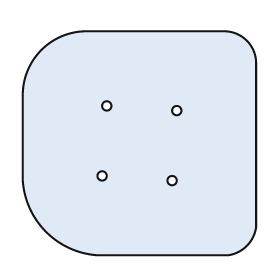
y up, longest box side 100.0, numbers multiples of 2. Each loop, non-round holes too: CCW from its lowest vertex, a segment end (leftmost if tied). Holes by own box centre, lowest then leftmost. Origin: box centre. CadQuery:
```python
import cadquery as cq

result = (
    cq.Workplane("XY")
    .moveTo(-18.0, -48.0)
    .lineTo(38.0, -48.0)
    .threePointArc((46.0, -44.0), (50.0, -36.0))
    .lineTo(50.0, 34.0)
    .threePointArc((46.0, 44.0), (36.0, 48.0))
    .lineTo(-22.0, 48.0)
    .threePointArc((-42.0, 40.0), (-50.0, 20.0))
    .lineTo(-50.0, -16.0)
    .threePointArc((-40.0, -38.0), (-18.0, -48.0))
    .close()
    .moveTo(14.0, -16.0)
    .circle(2.0)
    .moveTo(-16.0, -14.0)
    .circle(2.0)
    .moveTo(16.0, 14.0)
    .circle(2.0)
    .moveTo(-14.0, 16.0)
    .circle(2.0)
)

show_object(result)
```